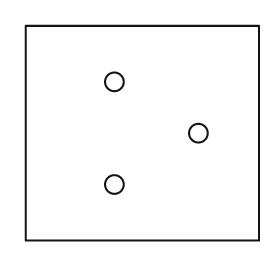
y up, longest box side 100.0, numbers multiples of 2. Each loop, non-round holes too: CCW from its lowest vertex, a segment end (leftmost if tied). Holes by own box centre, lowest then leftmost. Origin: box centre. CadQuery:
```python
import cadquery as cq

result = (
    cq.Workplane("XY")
    .moveTo(-50.0, -46.0)
    .lineTo(50.0, -46.0)
    .lineTo(50.0, 46.0)
    .lineTo(-50.0, 46.0)
    .close()
    .moveTo(-12.0, -22.0)
    .circle(4.0)
    .moveTo(24.0, 0.0)
    .circle(4.0)
    .moveTo(-12.0, 22.0)
    .circle(4.0)
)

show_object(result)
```